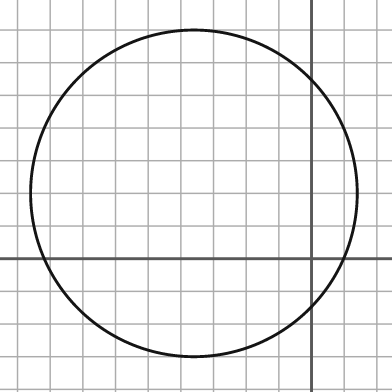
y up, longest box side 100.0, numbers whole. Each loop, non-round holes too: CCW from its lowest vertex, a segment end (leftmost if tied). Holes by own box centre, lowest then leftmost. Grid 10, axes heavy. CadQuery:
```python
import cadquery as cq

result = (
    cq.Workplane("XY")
    .moveTo(-36.0, 20.0)
    .circle(50.0)
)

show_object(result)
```